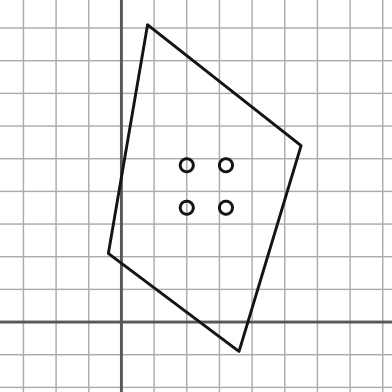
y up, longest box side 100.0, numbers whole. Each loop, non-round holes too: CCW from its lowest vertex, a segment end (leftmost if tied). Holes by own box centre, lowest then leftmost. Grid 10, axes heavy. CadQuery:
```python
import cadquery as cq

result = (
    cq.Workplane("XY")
    .moveTo(36.0, -9.0)
    .lineTo(55.0, 54.0)
    .lineTo(8.0, 91.0)
    .lineTo(-4.0, 21.0)
    .close()
    .moveTo(20.0, 35.0)
    .circle(2.0)
    .moveTo(32.0, 35.0)
    .circle(2.0)
    .moveTo(20.0, 48.0)
    .circle(2.0)
    .moveTo(32.0, 48.0)
    .circle(2.0)
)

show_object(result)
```